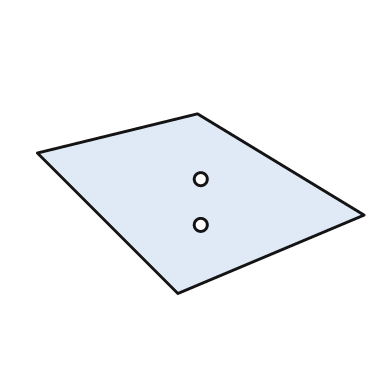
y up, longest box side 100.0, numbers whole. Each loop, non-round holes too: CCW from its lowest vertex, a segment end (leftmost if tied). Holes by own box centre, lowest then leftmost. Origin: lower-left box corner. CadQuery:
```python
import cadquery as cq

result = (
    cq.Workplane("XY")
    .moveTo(43.0, 0.0)
    .lineTo(100.0, 24.0)
    .lineTo(49.0, 55.0)
    .lineTo(0.0, 43.0)
    .close()
    .moveTo(50.0, 21.0)
    .circle(2.0)
    .moveTo(50.0, 35.0)
    .circle(2.0)
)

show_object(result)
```